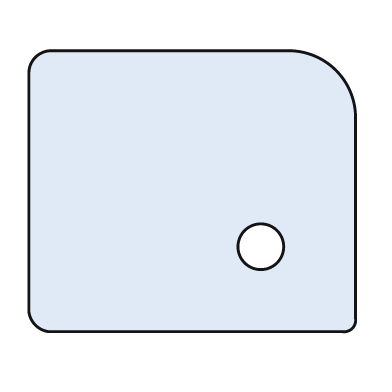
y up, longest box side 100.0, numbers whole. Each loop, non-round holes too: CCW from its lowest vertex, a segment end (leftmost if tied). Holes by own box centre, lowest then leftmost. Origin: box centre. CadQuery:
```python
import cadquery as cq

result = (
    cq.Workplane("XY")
    .moveTo(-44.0, -43.0)
    .lineTo(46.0, -43.0)
    .threePointArc((49.0, -42.0), (50.0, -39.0))
    .lineTo(50.0, 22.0)
    .threePointArc((44.0, 37.0), (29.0, 43.0))
    .lineTo(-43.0, 43.0)
    .threePointArc((-48.0, 41.0), (-50.0, 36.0))
    .lineTo(-50.0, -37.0)
    .threePointArc((-48.0, -41.0), (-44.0, -43.0))
    .close()
    .moveTo(21.0, -17.0)
    .circle(7.0)
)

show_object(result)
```